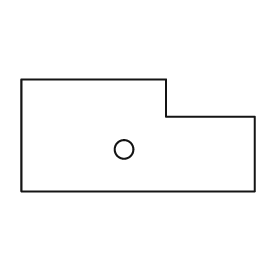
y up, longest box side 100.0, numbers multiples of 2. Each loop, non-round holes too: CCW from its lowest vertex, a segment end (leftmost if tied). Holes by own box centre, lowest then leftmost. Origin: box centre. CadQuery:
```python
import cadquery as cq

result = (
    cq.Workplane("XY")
    .moveTo(-50.0, -24.0)
    .lineTo(50.0, -24.0)
    .lineTo(50.0, 8.0)
    .lineTo(12.0, 8.0)
    .lineTo(12.0, 24.0)
    .lineTo(-50.0, 24.0)
    .close()
    .moveTo(-6.0, -6.0)
    .circle(4.0)
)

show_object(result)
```